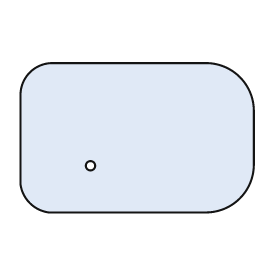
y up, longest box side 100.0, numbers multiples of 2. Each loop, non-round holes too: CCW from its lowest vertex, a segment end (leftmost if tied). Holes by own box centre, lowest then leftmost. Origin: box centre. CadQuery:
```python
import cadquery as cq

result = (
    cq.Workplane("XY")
    .moveTo(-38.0, -32.0)
    .lineTo(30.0, -32.0)
    .threePointArc((44.0, -26.0), (50.0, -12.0))
    .lineTo(50.0, 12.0)
    .threePointArc((44.0, 26.0), (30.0, 32.0))
    .lineTo(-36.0, 32.0)
    .threePointArc((-46.0, 28.0), (-50.0, 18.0))
    .lineTo(-50.0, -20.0)
    .threePointArc((-46.0, -28.0), (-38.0, -32.0))
    .close()
    .moveTo(-20.0, -12.0)
    .circle(2.0)
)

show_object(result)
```